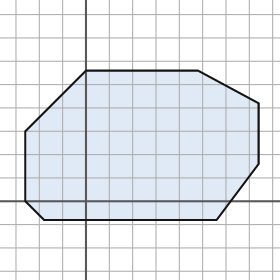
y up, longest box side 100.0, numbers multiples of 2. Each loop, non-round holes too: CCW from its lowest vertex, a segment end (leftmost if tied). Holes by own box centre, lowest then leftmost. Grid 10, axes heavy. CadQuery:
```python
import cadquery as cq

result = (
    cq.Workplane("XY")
    .moveTo(-18.0, -8.0)
    .lineTo(56.0, -8.0)
    .lineTo(74.0, 16.0)
    .lineTo(74.0, 42.0)
    .lineTo(48.0, 56.0)
    .lineTo(0.0, 56.0)
    .lineTo(-26.0, 30.0)
    .lineTo(-26.0, 0.0)
    .close()
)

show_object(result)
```